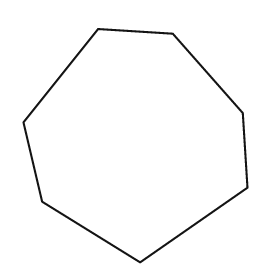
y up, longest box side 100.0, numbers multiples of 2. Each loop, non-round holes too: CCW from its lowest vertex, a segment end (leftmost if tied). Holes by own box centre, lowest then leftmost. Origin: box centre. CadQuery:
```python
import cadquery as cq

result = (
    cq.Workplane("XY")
    .moveTo(2.0, -50.0)
    .lineTo(48.0, -18.0)
    .lineTo(46.0, 14.0)
    .lineTo(16.0, 48.0)
    .lineTo(-16.0, 50.0)
    .lineTo(-48.0, 10.0)
    .lineTo(-40.0, -24.0)
    .close()
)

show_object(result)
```